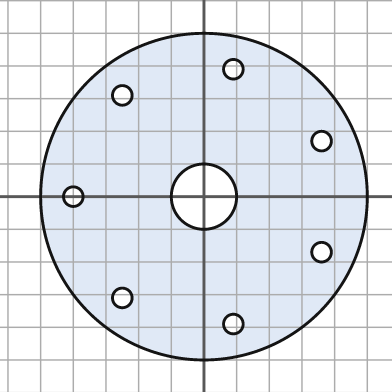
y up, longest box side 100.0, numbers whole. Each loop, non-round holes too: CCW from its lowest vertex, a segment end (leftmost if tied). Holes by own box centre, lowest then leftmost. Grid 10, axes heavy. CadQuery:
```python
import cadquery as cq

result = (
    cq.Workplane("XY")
    .moveTo(0.0, 0.0)
    .circle(50.0)
    .moveTo(9.0, -39.0)
    .circle(3.0)
    .moveTo(-25.0, -31.0)
    .circle(3.0)
    .moveTo(36.0, -17.0)
    .circle(3.0)
    .moveTo(-40.0, 0.0)
    .circle(3.0)
    .moveTo(0.0, 0.0)
    .circle(10.0)
    .moveTo(36.0, 17.0)
    .circle(3.0)
    .moveTo(-25.0, 31.0)
    .circle(3.0)
    .moveTo(9.0, 39.0)
    .circle(3.0)
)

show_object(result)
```